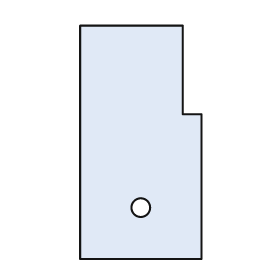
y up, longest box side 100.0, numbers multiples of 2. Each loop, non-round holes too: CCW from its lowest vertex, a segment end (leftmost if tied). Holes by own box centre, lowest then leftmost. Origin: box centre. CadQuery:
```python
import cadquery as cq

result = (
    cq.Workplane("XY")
    .moveTo(-26.0, -50.0)
    .lineTo(26.0, -50.0)
    .lineTo(26.0, 12.0)
    .lineTo(18.0, 12.0)
    .lineTo(18.0, 50.0)
    .lineTo(-26.0, 50.0)
    .close()
    .moveTo(0.0, -28.0)
    .circle(4.0)
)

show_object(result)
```